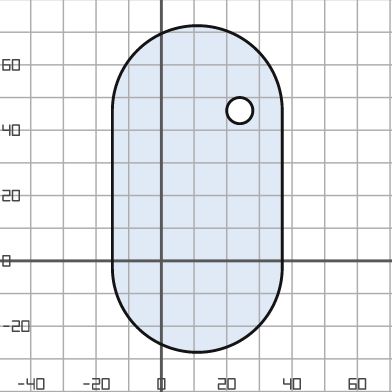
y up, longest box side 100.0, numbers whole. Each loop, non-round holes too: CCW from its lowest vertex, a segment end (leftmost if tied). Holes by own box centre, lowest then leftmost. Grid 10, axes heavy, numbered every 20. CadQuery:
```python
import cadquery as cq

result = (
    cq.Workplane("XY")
    .moveTo(-15.0, -2.0)
    .threePointArc((11.0, -28.0), (37.0, -2.0))
    .lineTo(37.0, 46.0)
    .threePointArc((11.0, 72.0), (-15.0, 46.0))
    .close()
    .moveTo(24.0, 46.0)
    .circle(4.0)
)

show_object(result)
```